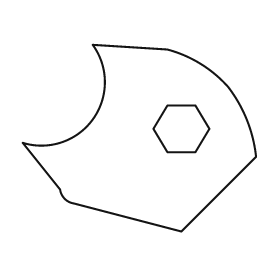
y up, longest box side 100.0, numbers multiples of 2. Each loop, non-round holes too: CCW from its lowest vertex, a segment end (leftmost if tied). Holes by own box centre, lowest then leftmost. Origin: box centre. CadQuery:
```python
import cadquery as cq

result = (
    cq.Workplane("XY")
    .moveTo(18.0, -40.0)
    .lineTo(50.0, -8.0)
    .threePointArc((46.0, 8.0), (38.0, 22.0))
    .threePointArc((26.0, 32.0), (12.0, 38.0))
    .lineTo(-20.0, 40.0)
    .threePointArc((-20.0, 8.0), (-50.0, -2.0))
    .lineTo(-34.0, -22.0)
    .threePointArc((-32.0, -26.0), (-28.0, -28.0))
    .close()
    .moveTo(12.0, -6.0)
    .lineTo(24.0, -6.0)
    .lineTo(30.0, 4.0)
    .lineTo(24.0, 14.0)
    .lineTo(12.0, 14.0)
    .lineTo(6.0, 4.0)
    .close()
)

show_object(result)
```